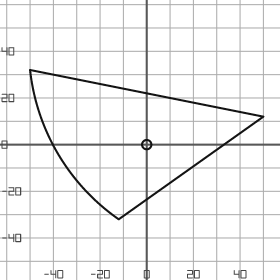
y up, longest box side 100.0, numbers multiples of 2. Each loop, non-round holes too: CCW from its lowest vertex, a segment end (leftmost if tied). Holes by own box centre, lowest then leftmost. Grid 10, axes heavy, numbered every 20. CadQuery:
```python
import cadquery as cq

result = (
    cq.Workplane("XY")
    .moveTo(-12.0, -32.0)
    .lineTo(50.0, 12.0)
    .lineTo(-50.0, 32.0)
    .threePointArc((-38.0, -4.0), (-12.0, -32.0))
    .close()
    .moveTo(0.0, 0.0)
    .circle(2.0)
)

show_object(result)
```